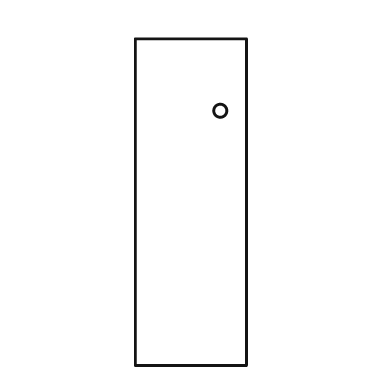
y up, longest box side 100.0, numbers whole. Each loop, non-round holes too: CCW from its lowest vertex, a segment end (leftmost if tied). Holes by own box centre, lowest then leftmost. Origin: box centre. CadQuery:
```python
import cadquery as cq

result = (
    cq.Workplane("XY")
    .moveTo(-17.0, -50.0)
    .lineTo(17.0, -50.0)
    .lineTo(17.0, 50.0)
    .lineTo(-17.0, 50.0)
    .close()
    .moveTo(9.0, 28.0)
    .circle(2.0)
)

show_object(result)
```